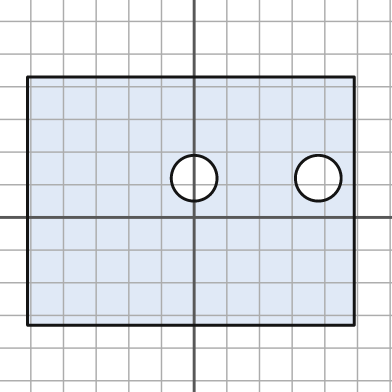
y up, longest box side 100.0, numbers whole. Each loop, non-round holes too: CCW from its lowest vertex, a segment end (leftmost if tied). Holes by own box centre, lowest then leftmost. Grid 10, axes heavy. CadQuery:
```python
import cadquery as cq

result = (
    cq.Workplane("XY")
    .moveTo(-51.0, -33.0)
    .lineTo(49.0, -33.0)
    .lineTo(49.0, 43.0)
    .lineTo(-51.0, 43.0)
    .close()
    .moveTo(0.0, 12.0)
    .circle(7.0)
    .moveTo(38.0, 12.0)
    .circle(7.0)
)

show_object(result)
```